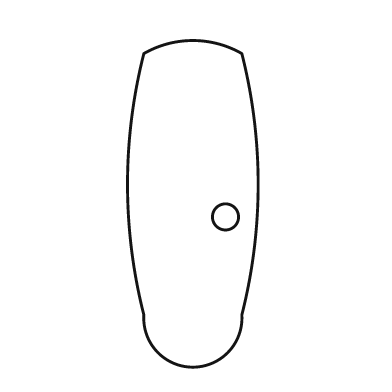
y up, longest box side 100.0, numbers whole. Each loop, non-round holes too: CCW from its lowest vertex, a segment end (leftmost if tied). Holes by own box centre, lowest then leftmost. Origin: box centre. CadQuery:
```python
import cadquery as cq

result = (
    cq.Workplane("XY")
    .moveTo(-15.0, -34.0)
    .threePointArc((0.0, -50.0), (15.0, -34.0))
    .threePointArc((20.0, 6.0), (15.0, 46.0))
    .threePointArc((0.0, 50.0), (-15.0, 46.0))
    .threePointArc((-20.0, 6.0), (-15.0, -34.0))
    .close()
    .moveTo(10.0, -4.0)
    .circle(4.0)
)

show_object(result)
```